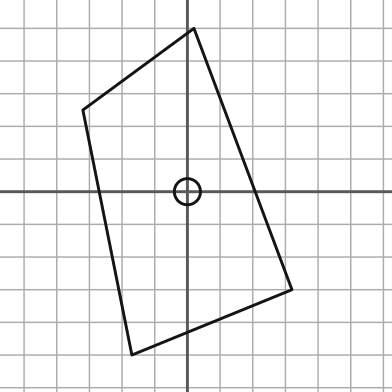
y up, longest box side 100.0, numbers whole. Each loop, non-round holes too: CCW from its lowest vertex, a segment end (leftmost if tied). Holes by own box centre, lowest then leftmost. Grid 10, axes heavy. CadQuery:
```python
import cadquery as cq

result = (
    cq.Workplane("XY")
    .moveTo(-17.0, -50.0)
    .lineTo(32.0, -30.0)
    .lineTo(2.0, 50.0)
    .lineTo(-32.0, 25.0)
    .close()
    .moveTo(0.0, 0.0)
    .circle(4.0)
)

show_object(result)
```